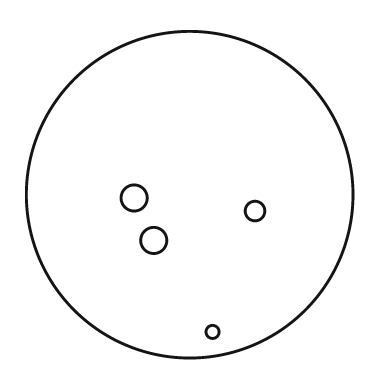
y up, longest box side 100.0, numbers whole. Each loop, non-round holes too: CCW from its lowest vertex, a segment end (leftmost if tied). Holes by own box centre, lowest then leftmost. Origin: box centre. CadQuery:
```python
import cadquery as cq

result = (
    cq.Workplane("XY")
    .moveTo(0.0, 0.0)
    .circle(50.0)
    .moveTo(7.0, -42.0)
    .circle(2.0)
    .moveTo(-11.0, -14.0)
    .circle(4.0)
    .moveTo(20.0, -5.0)
    .circle(3.0)
    .moveTo(-17.0, -1.0)
    .circle(4.0)
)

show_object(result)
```